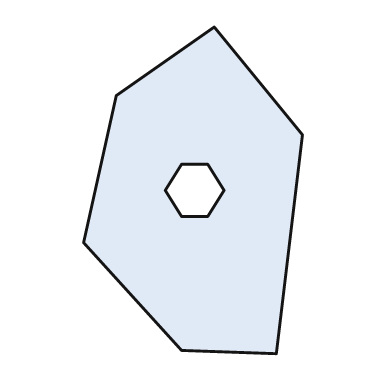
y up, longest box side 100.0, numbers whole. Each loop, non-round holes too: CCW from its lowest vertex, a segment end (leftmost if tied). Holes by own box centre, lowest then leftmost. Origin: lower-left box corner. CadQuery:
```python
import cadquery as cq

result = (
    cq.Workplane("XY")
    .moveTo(59.0, 0.0)
    .lineTo(67.0, 67.0)
    .lineTo(40.0, 100.0)
    .lineTo(10.0, 79.0)
    .lineTo(0.0, 34.0)
    .lineTo(30.0, 1.0)
    .close()
    .moveTo(30.0, 42.0)
    .lineTo(38.0, 42.0)
    .lineTo(43.0, 50.0)
    .lineTo(38.0, 58.0)
    .lineTo(30.0, 58.0)
    .lineTo(25.0, 50.0)
    .close()
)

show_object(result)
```